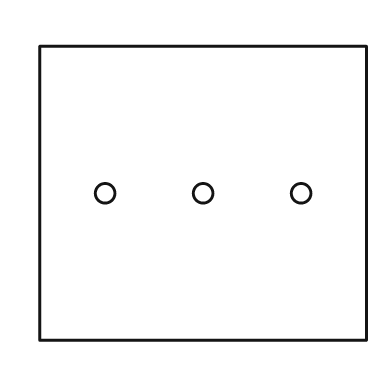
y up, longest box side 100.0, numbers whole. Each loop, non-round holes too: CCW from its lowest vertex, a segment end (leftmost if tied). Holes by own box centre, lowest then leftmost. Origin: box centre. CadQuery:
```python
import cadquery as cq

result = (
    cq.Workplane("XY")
    .moveTo(-50.0, -45.0)
    .lineTo(50.0, -45.0)
    .lineTo(50.0, 45.0)
    .lineTo(-50.0, 45.0)
    .close()
    .moveTo(-30.0, 0.0)
    .circle(3.0)
    .moveTo(0.0, 0.0)
    .circle(3.0)
    .moveTo(30.0, 0.0)
    .circle(3.0)
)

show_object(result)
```